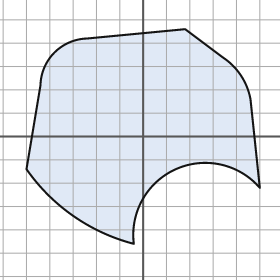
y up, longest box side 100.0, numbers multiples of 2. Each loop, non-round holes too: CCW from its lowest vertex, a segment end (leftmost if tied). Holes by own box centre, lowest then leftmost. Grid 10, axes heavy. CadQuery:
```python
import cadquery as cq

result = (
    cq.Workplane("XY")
    .moveTo(-4.0, -46.0)
    .threePointArc((14.0, -14.0), (50.0, -22.0))
    .lineTo(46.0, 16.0)
    .threePointArc((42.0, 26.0), (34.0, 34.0))
    .lineTo(18.0, 46.0)
    .lineTo(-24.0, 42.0)
    .threePointArc((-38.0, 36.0), (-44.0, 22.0))
    .lineTo(-50.0, -14.0)
    .threePointArc((-30.0, -34.0), (-4.0, -46.0))
    .close()
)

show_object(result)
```